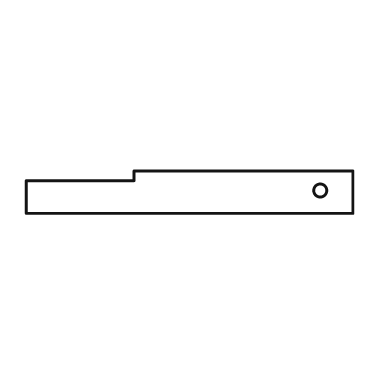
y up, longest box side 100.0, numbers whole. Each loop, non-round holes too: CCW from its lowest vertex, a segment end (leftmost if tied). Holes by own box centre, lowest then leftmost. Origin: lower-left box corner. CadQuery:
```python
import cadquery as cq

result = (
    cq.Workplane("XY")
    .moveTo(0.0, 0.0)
    .lineTo(100.0, 0.0)
    .lineTo(100.0, 13.0)
    .lineTo(33.0, 13.0)
    .lineTo(33.0, 10.0)
    .lineTo(0.0, 10.0)
    .close()
    .moveTo(90.0, 7.0)
    .circle(2.0)
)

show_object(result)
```